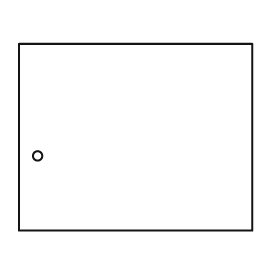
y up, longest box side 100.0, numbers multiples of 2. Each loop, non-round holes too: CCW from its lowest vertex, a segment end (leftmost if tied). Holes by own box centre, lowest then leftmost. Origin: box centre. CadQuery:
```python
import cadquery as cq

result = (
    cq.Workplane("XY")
    .moveTo(-50.0, -40.0)
    .lineTo(50.0, -40.0)
    .lineTo(50.0, 40.0)
    .lineTo(-50.0, 40.0)
    .close()
    .moveTo(-42.0, -8.0)
    .circle(2.0)
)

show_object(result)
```